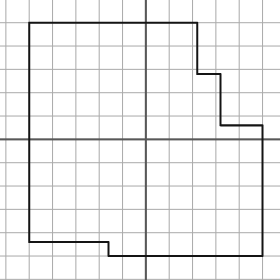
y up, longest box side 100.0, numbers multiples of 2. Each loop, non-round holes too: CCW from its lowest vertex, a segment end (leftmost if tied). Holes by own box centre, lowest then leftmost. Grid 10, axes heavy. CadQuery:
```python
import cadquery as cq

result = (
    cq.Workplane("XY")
    .moveTo(-16.0, -50.0)
    .lineTo(50.0, -50.0)
    .lineTo(50.0, 6.0)
    .lineTo(32.0, 6.0)
    .lineTo(32.0, 28.0)
    .lineTo(22.0, 28.0)
    .lineTo(22.0, 50.0)
    .lineTo(-50.0, 50.0)
    .lineTo(-50.0, -44.0)
    .lineTo(-16.0, -44.0)
    .close()
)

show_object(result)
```